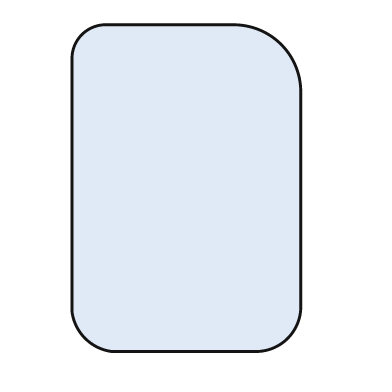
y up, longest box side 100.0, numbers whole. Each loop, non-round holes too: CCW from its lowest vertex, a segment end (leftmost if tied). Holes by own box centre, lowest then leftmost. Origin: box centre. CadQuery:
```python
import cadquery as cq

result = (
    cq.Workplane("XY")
    .moveTo(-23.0, -50.0)
    .lineTo(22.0, -50.0)
    .threePointArc((31.0, -46.0), (35.0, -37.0))
    .lineTo(35.0, 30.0)
    .threePointArc((29.0, 44.0), (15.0, 50.0))
    .lineTo(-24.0, 50.0)
    .threePointArc((-32.0, 47.0), (-35.0, 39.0))
    .lineTo(-35.0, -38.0)
    .threePointArc((-31.0, -46.0), (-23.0, -50.0))
    .close()
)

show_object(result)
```